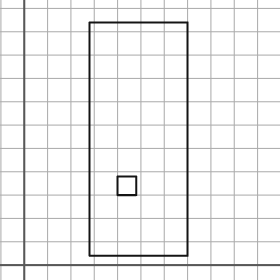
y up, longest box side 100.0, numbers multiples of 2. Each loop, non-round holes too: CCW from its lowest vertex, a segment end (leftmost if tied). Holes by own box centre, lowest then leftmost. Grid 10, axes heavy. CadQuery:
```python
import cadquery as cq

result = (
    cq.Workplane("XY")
    .moveTo(28.0, 4.0)
    .lineTo(70.0, 4.0)
    .lineTo(70.0, 104.0)
    .lineTo(28.0, 104.0)
    .close()
    .moveTo(40.0, 30.0)
    .lineTo(48.0, 30.0)
    .lineTo(48.0, 38.0)
    .lineTo(40.0, 38.0)
    .close()
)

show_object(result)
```